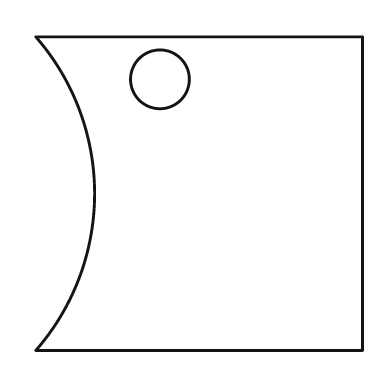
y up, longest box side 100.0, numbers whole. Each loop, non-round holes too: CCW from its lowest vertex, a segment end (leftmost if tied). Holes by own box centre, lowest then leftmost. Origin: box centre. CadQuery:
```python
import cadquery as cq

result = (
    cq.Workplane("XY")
    .moveTo(-50.0, -48.0)
    .lineTo(50.0, -48.0)
    .lineTo(50.0, 48.0)
    .lineTo(-50.0, 48.0)
    .threePointArc((-32.0, 0.0), (-50.0, -48.0))
    .close()
    .moveTo(-12.0, 35.0)
    .circle(9.0)
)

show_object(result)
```